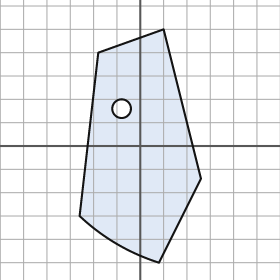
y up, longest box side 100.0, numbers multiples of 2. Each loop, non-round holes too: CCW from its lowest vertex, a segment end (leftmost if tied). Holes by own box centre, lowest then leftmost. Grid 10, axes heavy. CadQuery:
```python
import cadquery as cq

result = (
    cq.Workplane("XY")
    .moveTo(8.0, -50.0)
    .lineTo(26.0, -14.0)
    .lineTo(10.0, 50.0)
    .lineTo(-18.0, 40.0)
    .lineTo(-26.0, -30.0)
    .threePointArc((-10.0, -42.0), (8.0, -50.0))
    .close()
    .moveTo(-8.0, 16.0)
    .circle(4.0)
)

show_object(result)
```